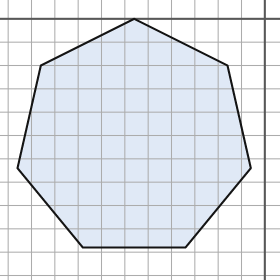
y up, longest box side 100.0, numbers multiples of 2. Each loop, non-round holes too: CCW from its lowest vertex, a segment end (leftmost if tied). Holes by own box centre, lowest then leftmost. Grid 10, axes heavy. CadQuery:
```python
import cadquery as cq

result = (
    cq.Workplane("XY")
    .moveTo(-78.0, -98.0)
    .lineTo(-34.0, -98.0)
    .lineTo(-6.0, -64.0)
    .lineTo(-16.0, -20.0)
    .lineTo(-56.0, 0.0)
    .lineTo(-96.0, -20.0)
    .lineTo(-106.0, -64.0)
    .close()
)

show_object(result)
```